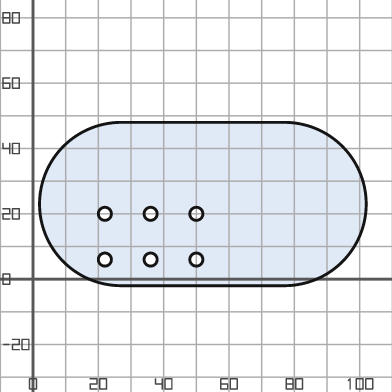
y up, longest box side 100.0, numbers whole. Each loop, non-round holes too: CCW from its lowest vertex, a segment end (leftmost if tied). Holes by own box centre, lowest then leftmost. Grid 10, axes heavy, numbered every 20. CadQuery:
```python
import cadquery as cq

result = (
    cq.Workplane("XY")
    .moveTo(27.0, -2.0)
    .lineTo(77.0, -2.0)
    .threePointArc((102.0, 23.0), (77.0, 48.0))
    .lineTo(27.0, 48.0)
    .threePointArc((2.0, 23.0), (27.0, -2.0))
    .close()
    .moveTo(22.0, 6.0)
    .circle(2.0)
    .moveTo(36.0, 6.0)
    .circle(2.0)
    .moveTo(50.0, 6.0)
    .circle(2.0)
    .moveTo(22.0, 20.0)
    .circle(2.0)
    .moveTo(36.0, 20.0)
    .circle(2.0)
    .moveTo(50.0, 20.0)
    .circle(2.0)
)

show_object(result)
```